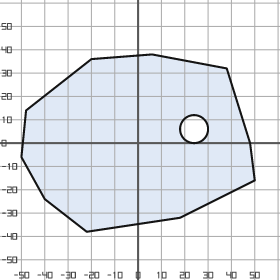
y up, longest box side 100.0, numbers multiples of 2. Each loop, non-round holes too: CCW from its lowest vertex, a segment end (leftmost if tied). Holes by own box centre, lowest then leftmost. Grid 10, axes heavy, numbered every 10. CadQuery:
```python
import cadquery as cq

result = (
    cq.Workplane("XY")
    .moveTo(-22.0, -38.0)
    .lineTo(18.0, -32.0)
    .lineTo(50.0, -16.0)
    .lineTo(48.0, 0.0)
    .lineTo(38.0, 32.0)
    .lineTo(6.0, 38.0)
    .lineTo(-20.0, 36.0)
    .lineTo(-48.0, 14.0)
    .lineTo(-50.0, -6.0)
    .lineTo(-40.0, -24.0)
    .close()
    .moveTo(24.0, 6.0)
    .circle(6.0)
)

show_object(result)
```